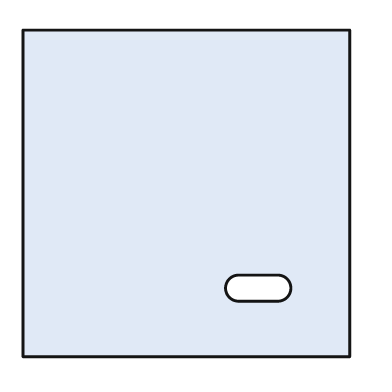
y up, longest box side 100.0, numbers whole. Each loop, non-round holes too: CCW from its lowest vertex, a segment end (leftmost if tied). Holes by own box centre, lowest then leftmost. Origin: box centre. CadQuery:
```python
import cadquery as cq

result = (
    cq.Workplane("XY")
    .moveTo(-50.0, -50.0)
    .lineTo(50.0, -50.0)
    .lineTo(50.0, 50.0)
    .lineTo(-50.0, 50.0)
    .close()
    .moveTo(16.0, -33.0)
    .lineTo(28.0, -33.0)
    .threePointArc((32.0, -29.0), (28.0, -25.0))
    .lineTo(16.0, -25.0)
    .threePointArc((12.0, -29.0), (16.0, -33.0))
    .close()
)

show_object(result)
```